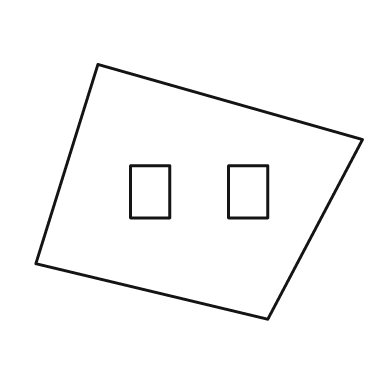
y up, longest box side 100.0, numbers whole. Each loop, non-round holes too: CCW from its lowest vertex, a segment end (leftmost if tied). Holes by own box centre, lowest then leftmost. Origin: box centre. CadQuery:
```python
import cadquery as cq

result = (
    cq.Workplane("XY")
    .moveTo(21.0, -39.0)
    .lineTo(50.0, 16.0)
    .lineTo(-31.0, 39.0)
    .lineTo(-50.0, -22.0)
    .close()
    .moveTo(-21.0, -8.0)
    .lineTo(-9.0, -8.0)
    .lineTo(-9.0, 8.0)
    .lineTo(-21.0, 8.0)
    .close()
    .moveTo(9.0, -8.0)
    .lineTo(21.0, -8.0)
    .lineTo(21.0, 8.0)
    .lineTo(9.0, 8.0)
    .close()
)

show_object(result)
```